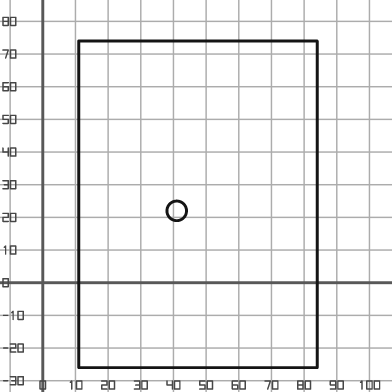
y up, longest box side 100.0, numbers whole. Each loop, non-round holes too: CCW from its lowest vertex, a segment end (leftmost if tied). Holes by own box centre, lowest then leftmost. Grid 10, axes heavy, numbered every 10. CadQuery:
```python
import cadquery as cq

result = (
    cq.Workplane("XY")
    .moveTo(11.0, -26.0)
    .lineTo(84.0, -26.0)
    .lineTo(84.0, 74.0)
    .lineTo(11.0, 74.0)
    .close()
    .moveTo(41.0, 22.0)
    .circle(3.0)
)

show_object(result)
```